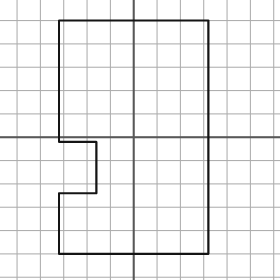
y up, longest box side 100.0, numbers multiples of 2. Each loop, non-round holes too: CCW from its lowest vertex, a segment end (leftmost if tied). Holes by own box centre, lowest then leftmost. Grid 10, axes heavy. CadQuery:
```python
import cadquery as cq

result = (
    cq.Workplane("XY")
    .moveTo(-32.0, -50.0)
    .lineTo(32.0, -50.0)
    .lineTo(32.0, 50.0)
    .lineTo(-32.0, 50.0)
    .lineTo(-32.0, -2.0)
    .lineTo(-16.0, -2.0)
    .lineTo(-16.0, -24.0)
    .lineTo(-32.0, -24.0)
    .close()
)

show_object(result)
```